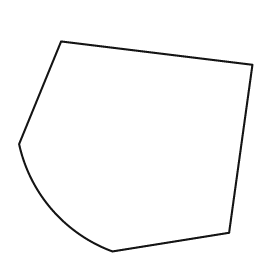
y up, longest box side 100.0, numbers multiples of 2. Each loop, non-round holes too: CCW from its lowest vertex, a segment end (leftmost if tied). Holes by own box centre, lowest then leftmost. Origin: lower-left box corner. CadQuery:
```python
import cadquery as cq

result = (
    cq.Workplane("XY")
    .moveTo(40.0, 0.0)
    .lineTo(90.0, 8.0)
    .lineTo(100.0, 80.0)
    .lineTo(18.0, 90.0)
    .lineTo(0.0, 46.0)
    .threePointArc((14.0, 18.0), (40.0, 0.0))
    .close()
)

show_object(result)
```